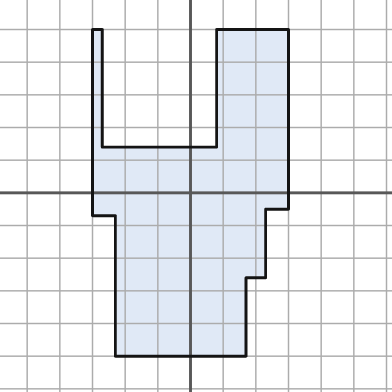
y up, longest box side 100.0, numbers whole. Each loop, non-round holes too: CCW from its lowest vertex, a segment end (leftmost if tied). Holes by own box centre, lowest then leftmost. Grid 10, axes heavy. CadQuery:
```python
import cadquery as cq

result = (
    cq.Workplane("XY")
    .moveTo(-23.0, -50.0)
    .lineTo(17.0, -50.0)
    .lineTo(17.0, -26.0)
    .lineTo(23.0, -26.0)
    .lineTo(23.0, -5.0)
    .lineTo(30.0, -5.0)
    .lineTo(30.0, 50.0)
    .lineTo(8.0, 50.0)
    .lineTo(8.0, 14.0)
    .lineTo(-27.0, 14.0)
    .lineTo(-27.0, 50.0)
    .lineTo(-30.0, 50.0)
    .lineTo(-30.0, -7.0)
    .lineTo(-23.0, -7.0)
    .close()
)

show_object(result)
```